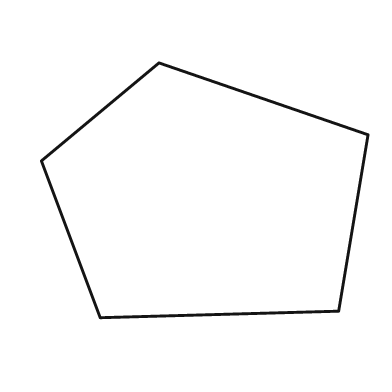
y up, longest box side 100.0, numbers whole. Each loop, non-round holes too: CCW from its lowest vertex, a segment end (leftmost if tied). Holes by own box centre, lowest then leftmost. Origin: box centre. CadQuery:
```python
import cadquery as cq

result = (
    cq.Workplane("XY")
    .moveTo(-32.0, -39.0)
    .lineTo(41.0, -37.0)
    .lineTo(50.0, 17.0)
    .lineTo(-14.0, 39.0)
    .lineTo(-50.0, 9.0)
    .close()
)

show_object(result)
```